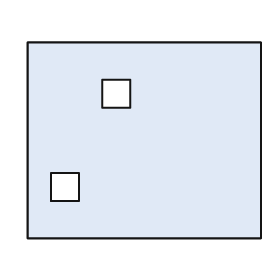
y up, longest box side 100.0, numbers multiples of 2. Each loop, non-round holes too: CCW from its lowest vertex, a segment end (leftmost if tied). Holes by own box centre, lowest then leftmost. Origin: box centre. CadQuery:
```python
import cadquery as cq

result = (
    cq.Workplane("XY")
    .moveTo(-50.0, -42.0)
    .lineTo(50.0, -42.0)
    .lineTo(50.0, 42.0)
    .lineTo(-50.0, 42.0)
    .close()
    .moveTo(-40.0, -26.0)
    .lineTo(-28.0, -26.0)
    .lineTo(-28.0, -14.0)
    .lineTo(-40.0, -14.0)
    .close()
    .moveTo(-18.0, 14.0)
    .lineTo(-6.0, 14.0)
    .lineTo(-6.0, 26.0)
    .lineTo(-18.0, 26.0)
    .close()
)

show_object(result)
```